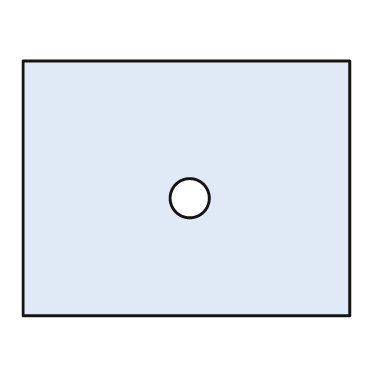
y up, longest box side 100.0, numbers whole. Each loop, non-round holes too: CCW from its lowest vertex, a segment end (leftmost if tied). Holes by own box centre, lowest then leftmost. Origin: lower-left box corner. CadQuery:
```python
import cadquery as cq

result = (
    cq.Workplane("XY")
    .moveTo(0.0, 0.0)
    .lineTo(100.0, 0.0)
    .lineTo(100.0, 78.0)
    .lineTo(0.0, 78.0)
    .close()
    .moveTo(51.0, 36.0)
    .circle(6.0)
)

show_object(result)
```